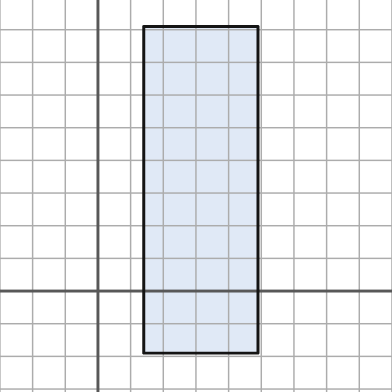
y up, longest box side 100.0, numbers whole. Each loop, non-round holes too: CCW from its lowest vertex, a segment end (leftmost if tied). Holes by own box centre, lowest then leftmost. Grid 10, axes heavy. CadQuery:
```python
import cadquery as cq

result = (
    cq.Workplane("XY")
    .moveTo(14.0, -19.0)
    .lineTo(49.0, -19.0)
    .lineTo(49.0, 81.0)
    .lineTo(14.0, 81.0)
    .close()
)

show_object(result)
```